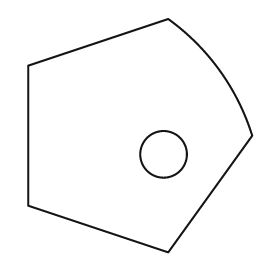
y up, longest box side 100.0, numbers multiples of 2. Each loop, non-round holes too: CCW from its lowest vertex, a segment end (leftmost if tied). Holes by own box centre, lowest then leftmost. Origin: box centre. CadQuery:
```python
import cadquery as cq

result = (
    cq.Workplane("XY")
    .moveTo(12.0, -50.0)
    .lineTo(48.0, 0.0)
    .threePointArc((34.0, 28.0), (12.0, 50.0))
    .lineTo(-48.0, 30.0)
    .lineTo(-48.0, -30.0)
    .close()
    .moveTo(10.0, -8.0)
    .circle(10.0)
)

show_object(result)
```